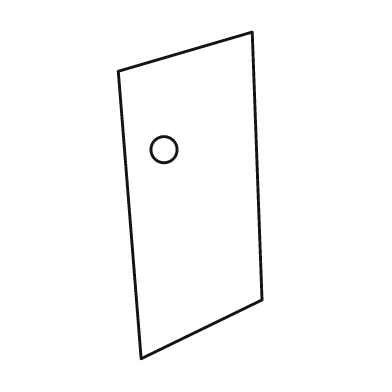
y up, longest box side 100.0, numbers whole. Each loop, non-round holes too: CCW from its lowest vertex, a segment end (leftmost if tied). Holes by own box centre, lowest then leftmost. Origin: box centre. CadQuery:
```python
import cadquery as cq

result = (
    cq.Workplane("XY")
    .moveTo(-15.0, -50.0)
    .lineTo(22.0, -32.0)
    .lineTo(19.0, 50.0)
    .lineTo(-22.0, 38.0)
    .close()
    .moveTo(-8.0, 14.0)
    .circle(4.0)
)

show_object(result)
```